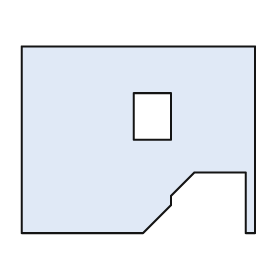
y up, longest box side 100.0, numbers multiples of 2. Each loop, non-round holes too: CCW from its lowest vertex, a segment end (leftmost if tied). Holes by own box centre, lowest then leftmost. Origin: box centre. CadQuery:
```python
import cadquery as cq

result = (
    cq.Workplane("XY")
    .moveTo(-50.0, -40.0)
    .lineTo(2.0, -40.0)
    .lineTo(14.0, -28.0)
    .lineTo(14.0, -24.0)
    .lineTo(24.0, -14.0)
    .lineTo(46.0, -14.0)
    .lineTo(46.0, -40.0)
    .lineTo(50.0, -40.0)
    .lineTo(50.0, 40.0)
    .lineTo(-50.0, 40.0)
    .close()
    .moveTo(-2.0, 0.0)
    .lineTo(14.0, 0.0)
    .lineTo(14.0, 20.0)
    .lineTo(-2.0, 20.0)
    .close()
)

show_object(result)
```